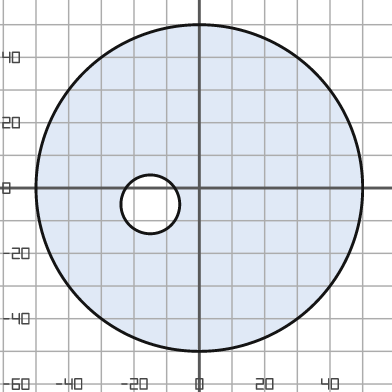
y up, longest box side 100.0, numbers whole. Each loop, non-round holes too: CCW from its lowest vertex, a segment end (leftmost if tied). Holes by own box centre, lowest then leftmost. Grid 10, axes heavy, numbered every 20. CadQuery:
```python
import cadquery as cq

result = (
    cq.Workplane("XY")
    .moveTo(0.0, 0.0)
    .circle(50.0)
    .moveTo(-15.0, -5.0)
    .circle(9.0)
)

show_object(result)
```